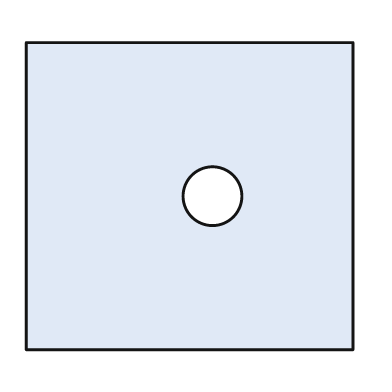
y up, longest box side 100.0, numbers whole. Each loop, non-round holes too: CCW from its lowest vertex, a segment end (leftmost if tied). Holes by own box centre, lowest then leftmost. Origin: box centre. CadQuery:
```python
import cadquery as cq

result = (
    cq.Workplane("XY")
    .moveTo(-50.0, -47.0)
    .lineTo(50.0, -47.0)
    .lineTo(50.0, 47.0)
    .lineTo(-50.0, 47.0)
    .close()
    .moveTo(7.0, 0.0)
    .circle(9.0)
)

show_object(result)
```